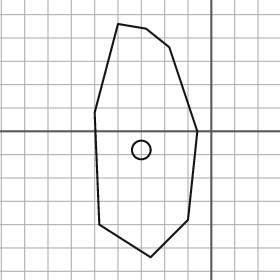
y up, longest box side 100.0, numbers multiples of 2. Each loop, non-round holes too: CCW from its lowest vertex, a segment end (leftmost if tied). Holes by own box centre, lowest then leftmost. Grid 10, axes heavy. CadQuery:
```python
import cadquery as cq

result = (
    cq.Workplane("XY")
    .moveTo(-26.0, -54.0)
    .lineTo(-10.0, -38.0)
    .lineTo(-6.0, 0.0)
    .lineTo(-18.0, 36.0)
    .lineTo(-28.0, 44.0)
    .lineTo(-40.0, 46.0)
    .lineTo(-50.0, 8.0)
    .lineTo(-48.0, -40.0)
    .close()
    .moveTo(-30.0, -8.0)
    .circle(4.0)
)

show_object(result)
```